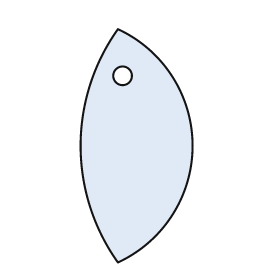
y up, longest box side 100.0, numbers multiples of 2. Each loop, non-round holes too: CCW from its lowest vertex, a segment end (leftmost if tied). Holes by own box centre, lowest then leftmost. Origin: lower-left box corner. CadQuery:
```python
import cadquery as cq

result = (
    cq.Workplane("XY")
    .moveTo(16.0, 0.0)
    .threePointArc((48.0, 50.0), (16.0, 100.0))
    .threePointArc((0.0, 50.0), (16.0, 0.0))
    .close()
    .moveTo(18.0, 80.0)
    .circle(4.0)
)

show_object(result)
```